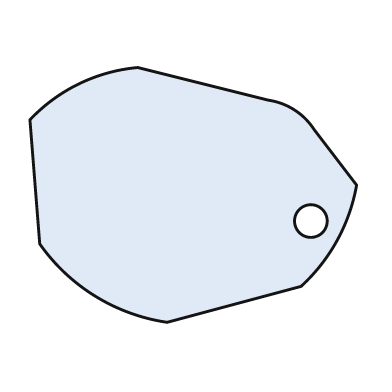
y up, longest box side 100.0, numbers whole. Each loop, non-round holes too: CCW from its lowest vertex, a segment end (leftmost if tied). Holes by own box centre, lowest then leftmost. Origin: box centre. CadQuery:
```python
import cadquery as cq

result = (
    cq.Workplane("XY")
    .moveTo(-8.0, -39.0)
    .lineTo(33.0, -28.0)
    .threePointArc((44.0, -14.0), (50.0, 3.0))
    .lineTo(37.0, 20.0)
    .threePointArc((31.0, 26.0), (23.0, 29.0))
    .lineTo(-17.0, 39.0)
    .threePointArc((-35.0, 34.0), (-50.0, 23.0))
    .lineTo(-47.0, -15.0)
    .threePointArc((-30.0, -31.0), (-8.0, -39.0))
    .close()
    .moveTo(36.0, -8.0)
    .circle(5.0)
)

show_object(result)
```